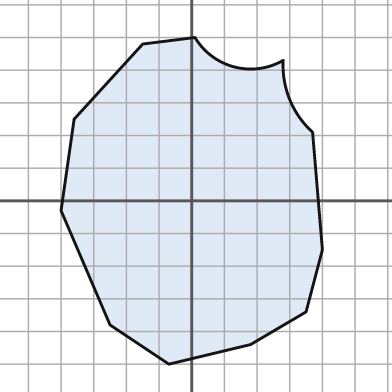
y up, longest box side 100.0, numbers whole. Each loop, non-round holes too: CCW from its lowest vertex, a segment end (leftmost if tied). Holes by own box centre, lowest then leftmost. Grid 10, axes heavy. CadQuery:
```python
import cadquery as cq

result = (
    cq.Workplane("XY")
    .moveTo(-7.0, -50.0)
    .lineTo(18.0, -44.0)
    .lineTo(35.0, -34.0)
    .lineTo(40.0, -15.0)
    .lineTo(37.0, 21.0)
    .threePointArc((30.0, 31.0), (28.0, 43.0))
    .threePointArc((13.0, 41.0), (1.0, 50.0))
    .lineTo(-15.0, 48.0)
    .lineTo(-36.0, 25.0)
    .lineTo(-40.0, -3.0)
    .lineTo(-25.0, -38.0)
    .close()
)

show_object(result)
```